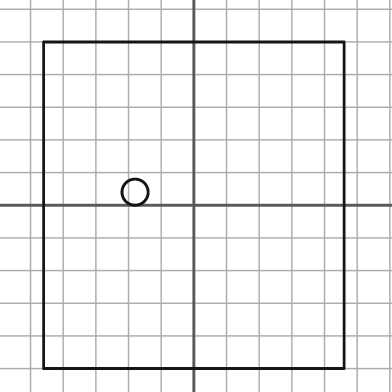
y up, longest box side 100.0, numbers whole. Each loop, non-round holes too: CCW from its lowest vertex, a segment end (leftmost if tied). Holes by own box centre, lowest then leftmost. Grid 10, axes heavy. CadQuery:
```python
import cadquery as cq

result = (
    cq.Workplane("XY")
    .moveTo(-46.0, -50.0)
    .lineTo(46.0, -50.0)
    .lineTo(46.0, 50.0)
    .lineTo(-46.0, 50.0)
    .close()
    .moveTo(-18.0, 4.0)
    .circle(4.0)
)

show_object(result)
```